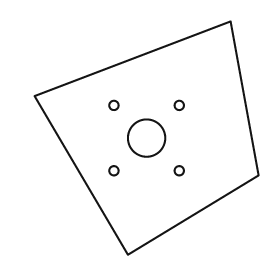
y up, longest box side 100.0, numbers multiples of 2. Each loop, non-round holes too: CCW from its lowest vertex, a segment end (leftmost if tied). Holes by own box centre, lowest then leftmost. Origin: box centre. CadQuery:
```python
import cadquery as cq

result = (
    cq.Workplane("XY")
    .moveTo(-8.0, -50.0)
    .lineTo(48.0, -16.0)
    .lineTo(36.0, 50.0)
    .lineTo(-48.0, 18.0)
    .close()
    .moveTo(-14.0, -14.0)
    .circle(2.0)
    .moveTo(14.0, -14.0)
    .circle(2.0)
    .moveTo(0.0, 0.0)
    .circle(8.0)
    .moveTo(-14.0, 14.0)
    .circle(2.0)
    .moveTo(14.0, 14.0)
    .circle(2.0)
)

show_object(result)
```